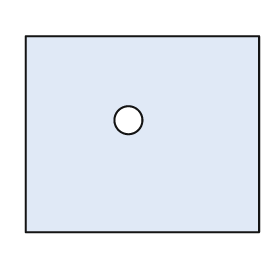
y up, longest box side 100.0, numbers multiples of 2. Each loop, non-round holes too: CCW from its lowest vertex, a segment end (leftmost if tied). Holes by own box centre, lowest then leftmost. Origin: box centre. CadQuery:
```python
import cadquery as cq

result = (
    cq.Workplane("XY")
    .moveTo(-50.0, -42.0)
    .lineTo(50.0, -42.0)
    .lineTo(50.0, 42.0)
    .lineTo(-50.0, 42.0)
    .close()
    .moveTo(-6.0, 6.0)
    .circle(6.0)
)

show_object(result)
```